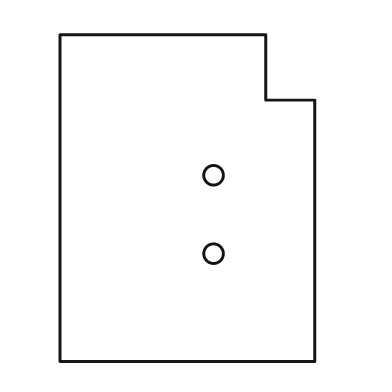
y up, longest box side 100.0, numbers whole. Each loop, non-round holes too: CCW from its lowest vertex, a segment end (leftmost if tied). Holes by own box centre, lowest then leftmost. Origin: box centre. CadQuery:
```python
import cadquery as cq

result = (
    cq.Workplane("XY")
    .moveTo(-39.0, -50.0)
    .lineTo(39.0, -50.0)
    .lineTo(39.0, 30.0)
    .lineTo(24.0, 30.0)
    .lineTo(24.0, 50.0)
    .lineTo(-39.0, 50.0)
    .close()
    .moveTo(8.0, -17.0)
    .circle(3.0)
    .moveTo(8.0, 7.0)
    .circle(3.0)
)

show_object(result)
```